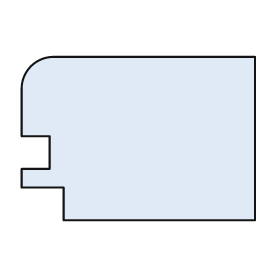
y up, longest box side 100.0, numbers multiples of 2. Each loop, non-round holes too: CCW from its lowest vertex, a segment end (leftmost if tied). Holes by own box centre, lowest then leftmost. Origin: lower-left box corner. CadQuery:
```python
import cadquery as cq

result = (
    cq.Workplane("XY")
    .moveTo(18.0, 0.0)
    .lineTo(100.0, 0.0)
    .lineTo(100.0, 70.0)
    .lineTo(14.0, 70.0)
    .threePointArc((4.0, 66.0), (0.0, 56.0))
    .lineTo(0.0, 36.0)
    .lineTo(12.0, 36.0)
    .lineTo(12.0, 22.0)
    .lineTo(0.0, 22.0)
    .lineTo(0.0, 14.0)
    .lineTo(18.0, 14.0)
    .close()
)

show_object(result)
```